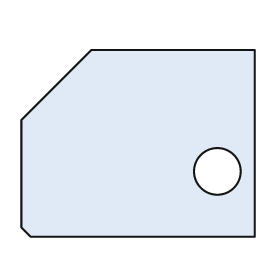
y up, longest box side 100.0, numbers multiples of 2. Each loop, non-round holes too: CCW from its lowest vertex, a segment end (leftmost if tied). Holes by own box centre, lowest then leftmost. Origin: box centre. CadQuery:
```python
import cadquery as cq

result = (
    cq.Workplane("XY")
    .moveTo(-46.0, -40.0)
    .lineTo(50.0, -40.0)
    .lineTo(50.0, 40.0)
    .lineTo(-20.0, 40.0)
    .lineTo(-50.0, 10.0)
    .lineTo(-50.0, -36.0)
    .close()
    .moveTo(34.0, -12.0)
    .circle(10.0)
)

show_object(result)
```